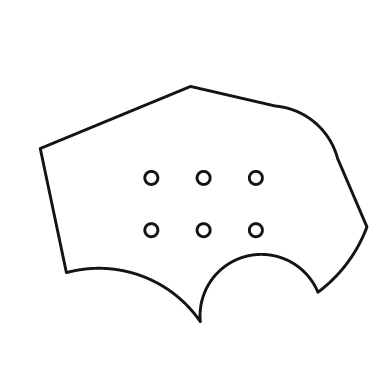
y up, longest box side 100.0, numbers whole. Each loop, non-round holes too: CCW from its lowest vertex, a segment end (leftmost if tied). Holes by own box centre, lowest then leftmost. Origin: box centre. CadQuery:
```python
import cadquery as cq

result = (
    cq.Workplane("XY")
    .moveTo(-1.0, -36.0)
    .threePointArc((13.0, -16.0), (35.0, -27.0))
    .threePointArc((44.0, -18.0), (50.0, -7.0))
    .lineTo(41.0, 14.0)
    .threePointArc((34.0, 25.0), (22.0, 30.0))
    .lineTo(-4.0, 36.0)
    .lineTo(-50.0, 17.0)
    .lineTo(-42.0, -21.0)
    .threePointArc((-19.0, -22.0), (-1.0, -36.0))
    .close()
    .moveTo(-16.0, -8.0)
    .circle(2.0)
    .moveTo(0.0, -8.0)
    .circle(2.0)
    .moveTo(16.0, -8.0)
    .circle(2.0)
    .moveTo(-16.0, 8.0)
    .circle(2.0)
    .moveTo(0.0, 8.0)
    .circle(2.0)
    .moveTo(16.0, 8.0)
    .circle(2.0)
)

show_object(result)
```